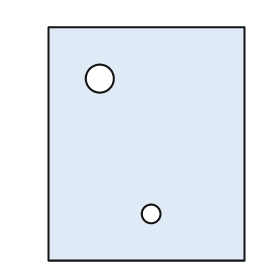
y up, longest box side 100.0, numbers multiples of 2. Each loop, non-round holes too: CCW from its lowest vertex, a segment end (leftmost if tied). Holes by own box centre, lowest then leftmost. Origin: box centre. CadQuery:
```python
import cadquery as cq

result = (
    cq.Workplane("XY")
    .moveTo(-42.0, -50.0)
    .lineTo(42.0, -50.0)
    .lineTo(42.0, 50.0)
    .lineTo(-42.0, 50.0)
    .close()
    .moveTo(2.0, -30.0)
    .circle(4.0)
    .moveTo(-20.0, 28.0)
    .circle(6.0)
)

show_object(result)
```